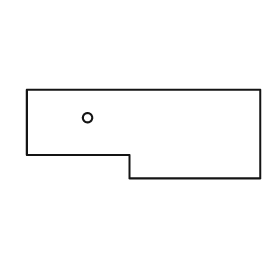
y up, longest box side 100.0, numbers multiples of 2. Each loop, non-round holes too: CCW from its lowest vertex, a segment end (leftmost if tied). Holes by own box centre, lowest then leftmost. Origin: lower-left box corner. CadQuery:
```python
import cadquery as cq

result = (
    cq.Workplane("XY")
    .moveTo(44.0, 0.0)
    .lineTo(100.0, 0.0)
    .lineTo(100.0, 38.0)
    .lineTo(0.0, 38.0)
    .lineTo(0.0, 10.0)
    .lineTo(44.0, 10.0)
    .close()
    .moveTo(26.0, 26.0)
    .circle(2.0)
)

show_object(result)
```